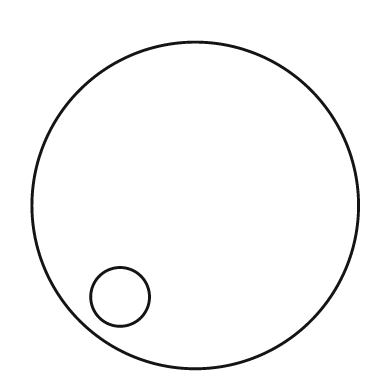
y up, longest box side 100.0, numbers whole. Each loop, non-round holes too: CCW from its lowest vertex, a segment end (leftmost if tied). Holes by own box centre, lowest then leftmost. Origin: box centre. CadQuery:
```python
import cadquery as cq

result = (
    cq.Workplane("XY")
    .moveTo(0.0, 0.0)
    .circle(50.0)
    .moveTo(-23.0, -28.0)
    .circle(9.0)
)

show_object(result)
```